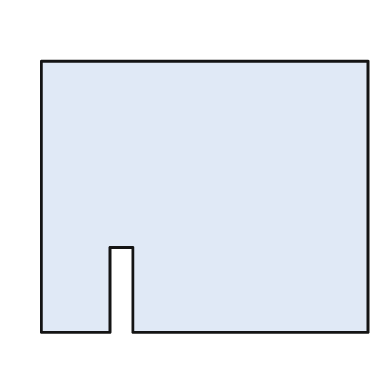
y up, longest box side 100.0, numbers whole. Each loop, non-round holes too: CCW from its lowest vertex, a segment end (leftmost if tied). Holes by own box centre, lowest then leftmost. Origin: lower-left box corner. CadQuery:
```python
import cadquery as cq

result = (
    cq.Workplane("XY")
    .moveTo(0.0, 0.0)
    .lineTo(21.0, 0.0)
    .lineTo(21.0, 26.0)
    .lineTo(28.0, 26.0)
    .lineTo(28.0, 0.0)
    .lineTo(100.0, 0.0)
    .lineTo(100.0, 83.0)
    .lineTo(0.0, 83.0)
    .close()
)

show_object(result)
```